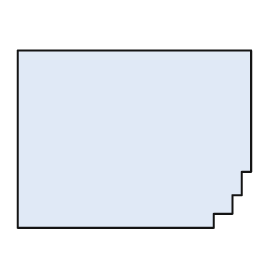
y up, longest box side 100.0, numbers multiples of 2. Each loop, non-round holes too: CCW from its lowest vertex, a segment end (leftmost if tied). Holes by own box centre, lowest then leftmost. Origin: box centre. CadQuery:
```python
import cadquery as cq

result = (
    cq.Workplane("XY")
    .moveTo(-50.0, -38.0)
    .lineTo(34.0, -38.0)
    .lineTo(34.0, -32.0)
    .lineTo(42.0, -32.0)
    .lineTo(42.0, -24.0)
    .lineTo(46.0, -24.0)
    .lineTo(46.0, -14.0)
    .lineTo(50.0, -14.0)
    .lineTo(50.0, 38.0)
    .lineTo(-50.0, 38.0)
    .close()
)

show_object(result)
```